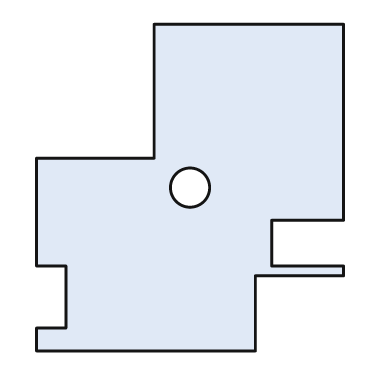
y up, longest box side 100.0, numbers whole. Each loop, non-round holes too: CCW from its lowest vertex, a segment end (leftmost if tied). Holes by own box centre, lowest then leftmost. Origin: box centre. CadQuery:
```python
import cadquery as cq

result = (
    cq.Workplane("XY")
    .moveTo(-47.0, -50.0)
    .lineTo(20.0, -50.0)
    .lineTo(20.0, -27.0)
    .lineTo(47.0, -27.0)
    .lineTo(47.0, -24.0)
    .lineTo(25.0, -24.0)
    .lineTo(25.0, -10.0)
    .lineTo(47.0, -10.0)
    .lineTo(47.0, 50.0)
    .lineTo(-11.0, 50.0)
    .lineTo(-11.0, 9.0)
    .lineTo(-47.0, 9.0)
    .lineTo(-47.0, -24.0)
    .lineTo(-38.0, -24.0)
    .lineTo(-38.0, -43.0)
    .lineTo(-47.0, -43.0)
    .close()
    .moveTo(0.0, 0.0)
    .circle(6.0)
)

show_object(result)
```